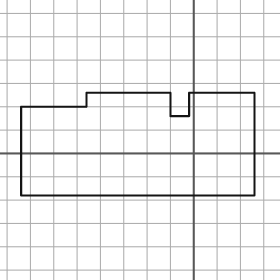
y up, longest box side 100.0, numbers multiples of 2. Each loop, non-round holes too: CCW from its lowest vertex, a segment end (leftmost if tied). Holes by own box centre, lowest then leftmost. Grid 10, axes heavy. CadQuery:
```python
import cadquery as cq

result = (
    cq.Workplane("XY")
    .moveTo(-74.0, -18.0)
    .lineTo(26.0, -18.0)
    .lineTo(26.0, 26.0)
    .lineTo(-2.0, 26.0)
    .lineTo(-2.0, 16.0)
    .lineTo(-10.0, 16.0)
    .lineTo(-10.0, 26.0)
    .lineTo(-46.0, 26.0)
    .lineTo(-46.0, 20.0)
    .lineTo(-74.0, 20.0)
    .close()
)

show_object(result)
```